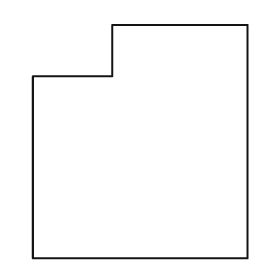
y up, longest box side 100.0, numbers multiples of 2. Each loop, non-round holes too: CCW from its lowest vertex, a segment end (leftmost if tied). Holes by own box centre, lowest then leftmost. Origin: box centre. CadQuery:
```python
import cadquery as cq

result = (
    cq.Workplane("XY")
    .moveTo(-46.0, -50.0)
    .lineTo(46.0, -50.0)
    .lineTo(46.0, 50.0)
    .lineTo(-12.0, 50.0)
    .lineTo(-12.0, 28.0)
    .lineTo(-46.0, 28.0)
    .close()
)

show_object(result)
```